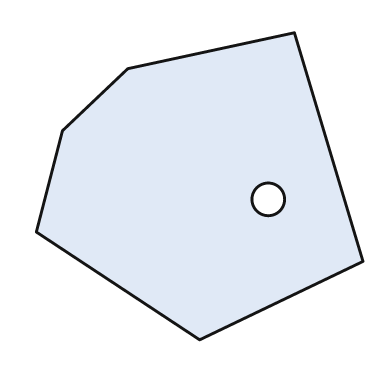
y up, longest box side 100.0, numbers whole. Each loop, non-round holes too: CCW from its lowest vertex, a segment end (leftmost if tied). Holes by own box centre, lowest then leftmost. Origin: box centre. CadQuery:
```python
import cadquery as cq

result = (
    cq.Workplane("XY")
    .moveTo(0.0, -47.0)
    .lineTo(50.0, -23.0)
    .lineTo(29.0, 47.0)
    .lineTo(-22.0, 36.0)
    .lineTo(-42.0, 17.0)
    .lineTo(-50.0, -14.0)
    .close()
    .moveTo(21.0, -4.0)
    .circle(5.0)
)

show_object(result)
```